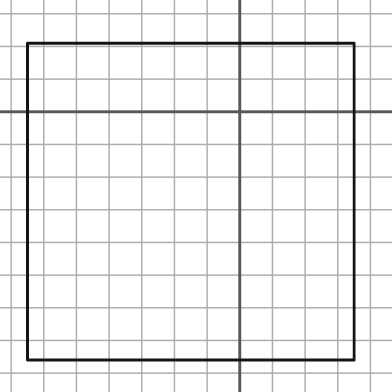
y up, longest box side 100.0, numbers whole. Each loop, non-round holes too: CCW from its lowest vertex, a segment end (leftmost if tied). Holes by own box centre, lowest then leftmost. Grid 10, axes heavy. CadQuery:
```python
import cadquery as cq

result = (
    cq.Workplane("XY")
    .moveTo(-65.0, -76.0)
    .lineTo(35.0, -76.0)
    .lineTo(35.0, 21.0)
    .lineTo(-65.0, 21.0)
    .close()
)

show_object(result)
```